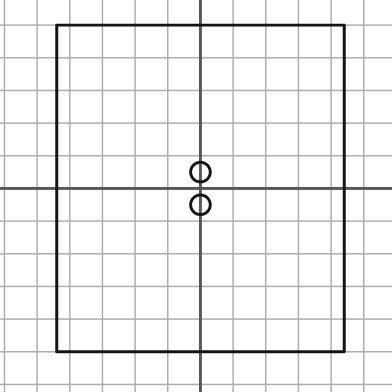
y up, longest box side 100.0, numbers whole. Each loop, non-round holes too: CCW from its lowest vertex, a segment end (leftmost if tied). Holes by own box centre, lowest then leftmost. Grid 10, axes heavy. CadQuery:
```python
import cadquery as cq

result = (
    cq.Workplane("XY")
    .moveTo(-44.0, -50.0)
    .lineTo(44.0, -50.0)
    .lineTo(44.0, 50.0)
    .lineTo(-44.0, 50.0)
    .close()
    .moveTo(0.0, -5.0)
    .circle(3.0)
    .moveTo(0.0, 5.0)
    .circle(3.0)
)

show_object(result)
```